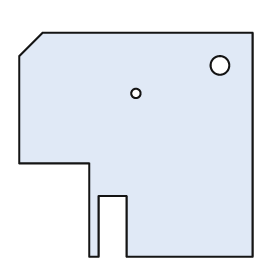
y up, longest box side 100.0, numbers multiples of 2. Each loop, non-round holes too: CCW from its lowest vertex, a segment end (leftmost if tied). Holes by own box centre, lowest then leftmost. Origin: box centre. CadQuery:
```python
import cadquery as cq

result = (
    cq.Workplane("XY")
    .moveTo(-20.0, -48.0)
    .lineTo(-16.0, -48.0)
    .lineTo(-16.0, -22.0)
    .lineTo(-4.0, -22.0)
    .lineTo(-4.0, -48.0)
    .lineTo(50.0, -48.0)
    .lineTo(50.0, 48.0)
    .lineTo(-40.0, 48.0)
    .lineTo(-50.0, 38.0)
    .lineTo(-50.0, -8.0)
    .lineTo(-20.0, -8.0)
    .close()
    .moveTo(0.0, 22.0)
    .circle(2.0)
    .moveTo(36.0, 34.0)
    .circle(4.0)
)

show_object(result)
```